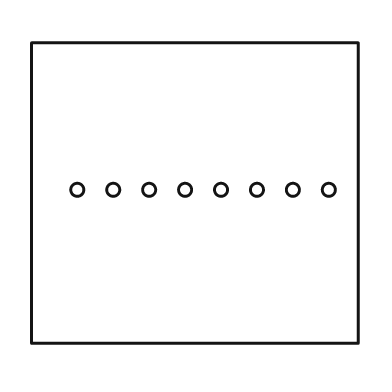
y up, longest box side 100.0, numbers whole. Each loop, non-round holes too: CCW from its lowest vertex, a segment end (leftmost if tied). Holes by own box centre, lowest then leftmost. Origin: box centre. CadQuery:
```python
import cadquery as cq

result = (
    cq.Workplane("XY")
    .moveTo(-50.0, -46.0)
    .lineTo(50.0, -46.0)
    .lineTo(50.0, 46.0)
    .lineTo(-50.0, 46.0)
    .close()
    .moveTo(-36.0, 1.0)
    .circle(2.0)
    .moveTo(-25.0, 1.0)
    .circle(2.0)
    .moveTo(-14.0, 1.0)
    .circle(2.0)
    .moveTo(-3.0, 1.0)
    .circle(2.0)
    .moveTo(8.0, 1.0)
    .circle(2.0)
    .moveTo(19.0, 1.0)
    .circle(2.0)
    .moveTo(30.0, 1.0)
    .circle(2.0)
    .moveTo(41.0, 1.0)
    .circle(2.0)
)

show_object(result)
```